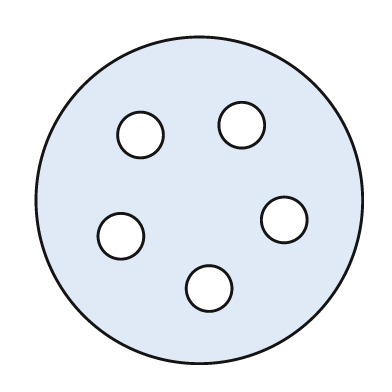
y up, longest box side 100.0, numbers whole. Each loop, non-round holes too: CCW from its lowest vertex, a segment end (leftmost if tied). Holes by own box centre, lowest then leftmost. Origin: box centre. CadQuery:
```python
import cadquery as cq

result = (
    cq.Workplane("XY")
    .moveTo(0.0, 0.0)
    .circle(50.0)
    .moveTo(3.0, -27.0)
    .circle(7.0)
    .moveTo(-24.0, -11.0)
    .circle(7.0)
    .moveTo(26.0, -6.0)
    .circle(7.0)
    .moveTo(-18.0, 20.0)
    .circle(7.0)
    .moveTo(13.0, 23.0)
    .circle(7.0)
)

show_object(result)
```